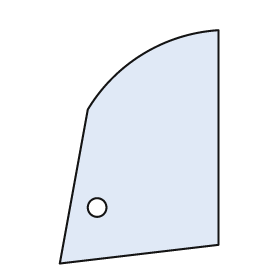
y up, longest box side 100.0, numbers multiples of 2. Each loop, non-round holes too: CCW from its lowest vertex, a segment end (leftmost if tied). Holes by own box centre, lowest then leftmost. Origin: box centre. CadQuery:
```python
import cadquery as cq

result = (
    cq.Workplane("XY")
    .moveTo(-34.0, -50.0)
    .lineTo(34.0, -42.0)
    .lineTo(34.0, 50.0)
    .threePointArc((2.0, 40.0), (-22.0, 16.0))
    .close()
    .moveTo(-18.0, -26.0)
    .circle(4.0)
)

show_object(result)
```